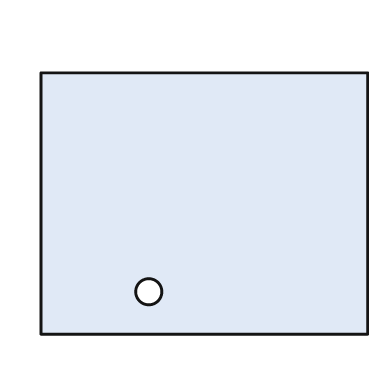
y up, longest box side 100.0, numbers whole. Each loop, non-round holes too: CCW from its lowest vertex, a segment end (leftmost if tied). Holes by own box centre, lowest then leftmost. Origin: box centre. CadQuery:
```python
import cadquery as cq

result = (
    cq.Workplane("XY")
    .moveTo(-50.0, -40.0)
    .lineTo(50.0, -40.0)
    .lineTo(50.0, 40.0)
    .lineTo(-50.0, 40.0)
    .close()
    .moveTo(-17.0, -27.0)
    .circle(4.0)
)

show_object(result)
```